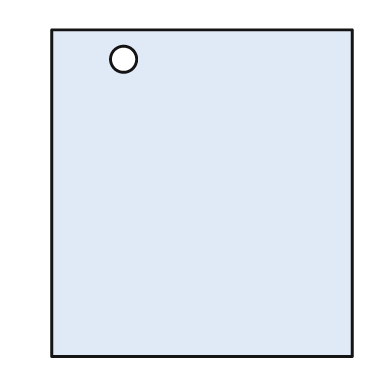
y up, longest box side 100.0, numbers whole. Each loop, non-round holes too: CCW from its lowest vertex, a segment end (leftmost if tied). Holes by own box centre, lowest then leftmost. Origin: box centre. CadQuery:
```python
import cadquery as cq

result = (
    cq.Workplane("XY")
    .moveTo(-46.0, -50.0)
    .lineTo(46.0, -50.0)
    .lineTo(46.0, 50.0)
    .lineTo(-46.0, 50.0)
    .close()
    .moveTo(-24.0, 41.0)
    .circle(4.0)
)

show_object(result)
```